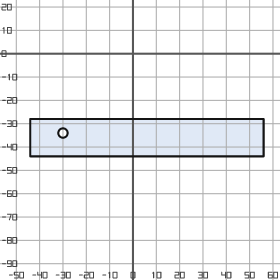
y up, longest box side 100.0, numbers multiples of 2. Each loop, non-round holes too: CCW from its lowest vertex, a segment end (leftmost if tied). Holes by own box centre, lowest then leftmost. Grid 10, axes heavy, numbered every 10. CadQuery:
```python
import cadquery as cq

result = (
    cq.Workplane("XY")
    .moveTo(-44.0, -44.0)
    .lineTo(56.0, -44.0)
    .lineTo(56.0, -28.0)
    .lineTo(-44.0, -28.0)
    .close()
    .moveTo(-30.0, -34.0)
    .circle(2.0)
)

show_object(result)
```